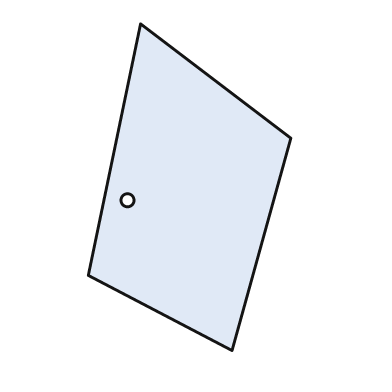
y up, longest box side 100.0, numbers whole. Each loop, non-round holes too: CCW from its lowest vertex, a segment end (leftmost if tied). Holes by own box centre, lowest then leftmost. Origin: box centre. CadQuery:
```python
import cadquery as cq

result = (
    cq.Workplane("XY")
    .moveTo(13.0, -50.0)
    .lineTo(31.0, 15.0)
    .lineTo(-15.0, 50.0)
    .lineTo(-31.0, -27.0)
    .close()
    .moveTo(-19.0, -4.0)
    .circle(2.0)
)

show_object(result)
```